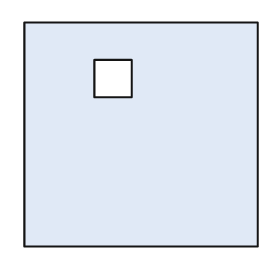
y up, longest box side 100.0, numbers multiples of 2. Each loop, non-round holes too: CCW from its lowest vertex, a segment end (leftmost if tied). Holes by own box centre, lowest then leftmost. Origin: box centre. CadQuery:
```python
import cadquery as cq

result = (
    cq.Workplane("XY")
    .moveTo(-50.0, -48.0)
    .lineTo(50.0, -48.0)
    .lineTo(50.0, 48.0)
    .lineTo(-50.0, 48.0)
    .close()
    .moveTo(-20.0, 16.0)
    .lineTo(-4.0, 16.0)
    .lineTo(-4.0, 32.0)
    .lineTo(-20.0, 32.0)
    .close()
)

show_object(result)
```